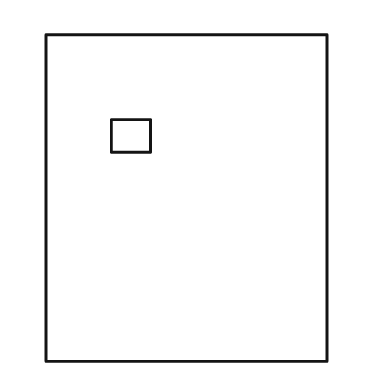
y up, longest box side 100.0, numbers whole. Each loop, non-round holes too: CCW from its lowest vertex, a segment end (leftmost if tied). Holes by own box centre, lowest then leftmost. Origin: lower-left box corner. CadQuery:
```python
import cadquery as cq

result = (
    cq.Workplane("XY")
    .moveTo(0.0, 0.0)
    .lineTo(86.0, 0.0)
    .lineTo(86.0, 100.0)
    .lineTo(0.0, 100.0)
    .close()
    .moveTo(20.0, 64.0)
    .lineTo(32.0, 64.0)
    .lineTo(32.0, 74.0)
    .lineTo(20.0, 74.0)
    .close()
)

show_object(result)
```